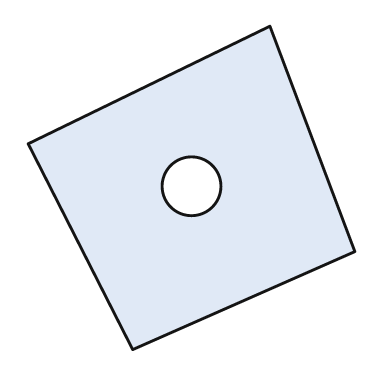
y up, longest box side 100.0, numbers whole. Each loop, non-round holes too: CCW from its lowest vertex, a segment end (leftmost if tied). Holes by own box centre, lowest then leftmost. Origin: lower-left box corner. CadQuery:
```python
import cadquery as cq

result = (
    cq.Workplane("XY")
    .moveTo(32.0, 0.0)
    .lineTo(100.0, 30.0)
    .lineTo(74.0, 99.0)
    .lineTo(0.0, 63.0)
    .close()
    .moveTo(50.0, 50.0)
    .circle(9.0)
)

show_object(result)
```